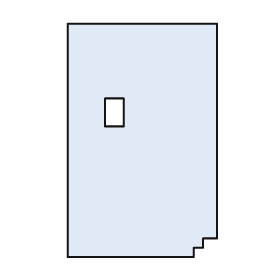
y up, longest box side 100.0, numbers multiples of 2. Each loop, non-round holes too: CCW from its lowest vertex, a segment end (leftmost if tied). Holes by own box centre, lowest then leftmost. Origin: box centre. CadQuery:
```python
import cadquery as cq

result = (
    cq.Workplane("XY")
    .moveTo(-32.0, -50.0)
    .lineTo(22.0, -50.0)
    .lineTo(22.0, -46.0)
    .lineTo(26.0, -46.0)
    .lineTo(26.0, -42.0)
    .lineTo(32.0, -42.0)
    .lineTo(32.0, 50.0)
    .lineTo(-32.0, 50.0)
    .close()
    .moveTo(-16.0, 6.0)
    .lineTo(-8.0, 6.0)
    .lineTo(-8.0, 18.0)
    .lineTo(-16.0, 18.0)
    .close()
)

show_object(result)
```